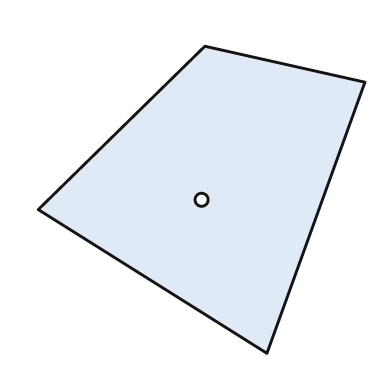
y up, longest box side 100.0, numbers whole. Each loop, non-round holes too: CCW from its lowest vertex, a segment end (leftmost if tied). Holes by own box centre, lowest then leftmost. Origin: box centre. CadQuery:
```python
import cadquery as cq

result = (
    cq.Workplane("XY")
    .moveTo(20.0, -47.0)
    .lineTo(50.0, 36.0)
    .lineTo(1.0, 47.0)
    .lineTo(-50.0, -3.0)
    .close()
    .moveTo(0.0, 0.0)
    .circle(2.0)
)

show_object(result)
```